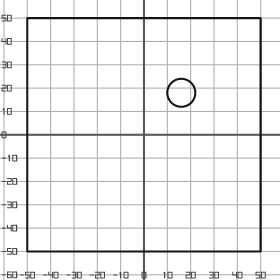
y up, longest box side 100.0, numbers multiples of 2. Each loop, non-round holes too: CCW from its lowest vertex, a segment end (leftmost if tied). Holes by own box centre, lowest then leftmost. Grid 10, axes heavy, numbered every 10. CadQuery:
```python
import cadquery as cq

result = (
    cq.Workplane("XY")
    .moveTo(-50.0, -50.0)
    .lineTo(50.0, -50.0)
    .lineTo(50.0, 50.0)
    .lineTo(-50.0, 50.0)
    .close()
    .moveTo(16.0, 18.0)
    .circle(6.0)
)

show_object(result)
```